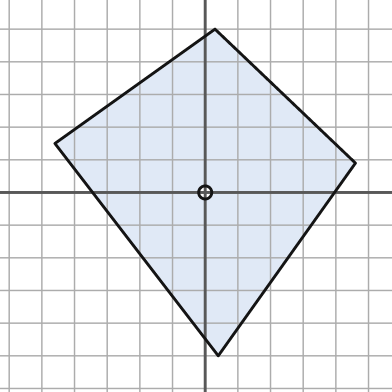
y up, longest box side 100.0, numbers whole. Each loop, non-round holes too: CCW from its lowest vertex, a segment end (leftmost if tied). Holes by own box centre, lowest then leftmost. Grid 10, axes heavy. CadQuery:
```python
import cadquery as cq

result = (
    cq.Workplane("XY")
    .moveTo(4.0, -50.0)
    .lineTo(46.0, 9.0)
    .lineTo(3.0, 50.0)
    .lineTo(-46.0, 15.0)
    .close()
    .moveTo(0.0, 0.0)
    .circle(2.0)
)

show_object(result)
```